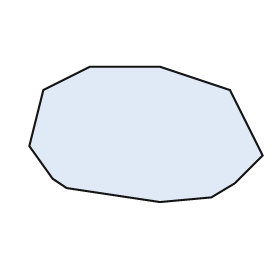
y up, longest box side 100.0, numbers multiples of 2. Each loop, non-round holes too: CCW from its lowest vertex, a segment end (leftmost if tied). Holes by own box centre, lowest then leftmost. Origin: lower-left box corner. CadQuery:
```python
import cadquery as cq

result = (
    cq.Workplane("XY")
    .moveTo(56.0, 0.0)
    .lineTo(78.0, 2.0)
    .lineTo(88.0, 8.0)
    .lineTo(100.0, 20.0)
    .lineTo(86.0, 48.0)
    .lineTo(56.0, 58.0)
    .lineTo(26.0, 58.0)
    .lineTo(6.0, 48.0)
    .lineTo(0.0, 24.0)
    .lineTo(10.0, 10.0)
    .lineTo(16.0, 6.0)
    .close()
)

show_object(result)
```